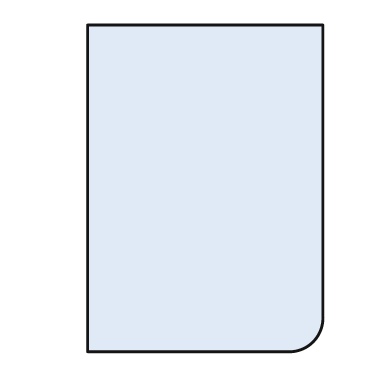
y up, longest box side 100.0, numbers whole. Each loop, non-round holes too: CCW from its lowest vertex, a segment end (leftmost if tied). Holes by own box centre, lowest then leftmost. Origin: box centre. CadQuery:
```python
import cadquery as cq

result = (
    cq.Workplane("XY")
    .moveTo(-36.0, -50.0)
    .lineTo(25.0, -50.0)
    .threePointArc((33.0, -47.0), (36.0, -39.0))
    .lineTo(36.0, 50.0)
    .lineTo(-36.0, 50.0)
    .close()
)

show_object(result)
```